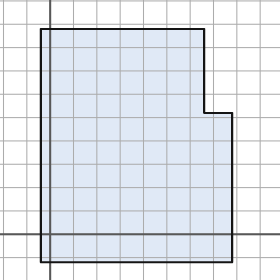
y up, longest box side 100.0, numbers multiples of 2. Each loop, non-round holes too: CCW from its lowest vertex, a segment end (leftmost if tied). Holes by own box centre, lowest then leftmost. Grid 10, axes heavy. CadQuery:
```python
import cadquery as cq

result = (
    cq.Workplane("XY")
    .moveTo(-4.0, -12.0)
    .lineTo(78.0, -12.0)
    .lineTo(78.0, 52.0)
    .lineTo(66.0, 52.0)
    .lineTo(66.0, 88.0)
    .lineTo(-4.0, 88.0)
    .close()
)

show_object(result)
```